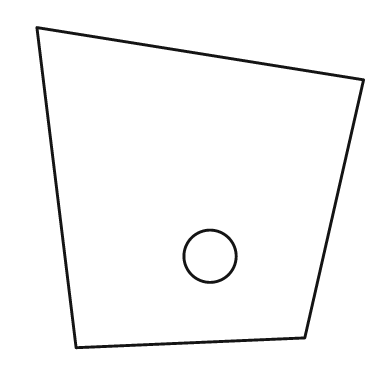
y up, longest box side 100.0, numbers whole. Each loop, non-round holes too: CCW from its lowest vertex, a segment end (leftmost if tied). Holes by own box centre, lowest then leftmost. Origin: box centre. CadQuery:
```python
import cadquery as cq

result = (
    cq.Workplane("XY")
    .moveTo(-38.0, -49.0)
    .lineTo(32.0, -46.0)
    .lineTo(50.0, 33.0)
    .lineTo(-50.0, 49.0)
    .close()
    .moveTo(3.0, -21.0)
    .circle(8.0)
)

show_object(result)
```